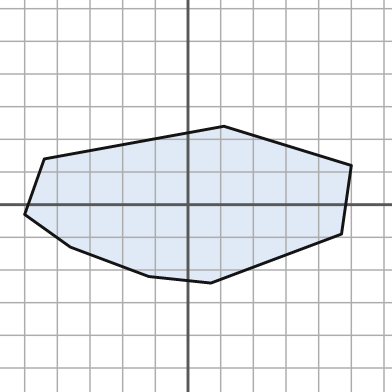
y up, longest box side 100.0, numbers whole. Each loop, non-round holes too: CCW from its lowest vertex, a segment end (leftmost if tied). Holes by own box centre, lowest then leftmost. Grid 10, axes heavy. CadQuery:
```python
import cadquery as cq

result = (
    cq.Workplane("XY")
    .moveTo(7.0, -24.0)
    .lineTo(47.0, -9.0)
    .lineTo(50.0, 12.0)
    .lineTo(11.0, 24.0)
    .lineTo(-44.0, 14.0)
    .lineTo(-50.0, -3.0)
    .lineTo(-36.0, -13.0)
    .lineTo(-12.0, -22.0)
    .close()
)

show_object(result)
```